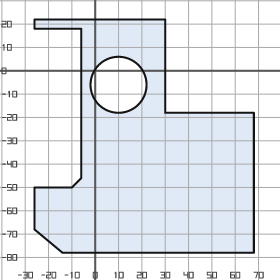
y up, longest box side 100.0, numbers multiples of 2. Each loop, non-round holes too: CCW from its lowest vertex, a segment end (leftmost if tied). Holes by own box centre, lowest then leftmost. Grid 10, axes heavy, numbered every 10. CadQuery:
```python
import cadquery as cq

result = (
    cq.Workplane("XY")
    .moveTo(-14.0, -78.0)
    .lineTo(68.0, -78.0)
    .lineTo(68.0, -18.0)
    .lineTo(30.0, -18.0)
    .lineTo(30.0, 22.0)
    .lineTo(-26.0, 22.0)
    .lineTo(-26.0, 18.0)
    .lineTo(-6.0, 18.0)
    .lineTo(-6.0, -46.0)
    .lineTo(-10.0, -50.0)
    .lineTo(-26.0, -50.0)
    .lineTo(-26.0, -68.0)
    .close()
    .moveTo(10.0, -6.0)
    .circle(12.0)
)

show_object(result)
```